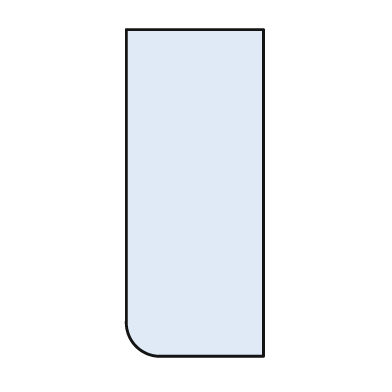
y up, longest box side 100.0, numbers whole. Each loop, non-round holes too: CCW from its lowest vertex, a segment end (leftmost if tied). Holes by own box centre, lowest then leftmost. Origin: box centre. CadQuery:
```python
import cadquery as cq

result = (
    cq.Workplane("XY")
    .moveTo(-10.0, -50.0)
    .lineTo(21.0, -50.0)
    .lineTo(21.0, 50.0)
    .lineTo(-21.0, 50.0)
    .lineTo(-21.0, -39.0)
    .threePointArc((-18.0, -47.0), (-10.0, -50.0))
    .close()
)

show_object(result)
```